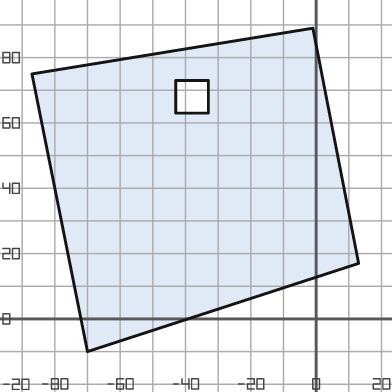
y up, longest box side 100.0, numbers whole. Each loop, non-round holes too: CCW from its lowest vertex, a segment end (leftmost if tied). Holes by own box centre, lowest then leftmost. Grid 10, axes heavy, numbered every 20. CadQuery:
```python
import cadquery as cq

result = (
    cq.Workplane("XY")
    .moveTo(-70.0, -10.0)
    .lineTo(13.0, 17.0)
    .lineTo(-1.0, 89.0)
    .lineTo(-87.0, 75.0)
    .close()
    .moveTo(-43.0, 63.0)
    .lineTo(-33.0, 63.0)
    .lineTo(-33.0, 73.0)
    .lineTo(-43.0, 73.0)
    .close()
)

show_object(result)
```